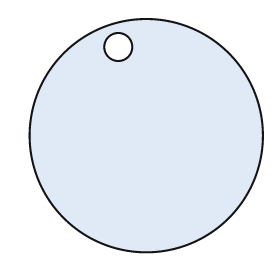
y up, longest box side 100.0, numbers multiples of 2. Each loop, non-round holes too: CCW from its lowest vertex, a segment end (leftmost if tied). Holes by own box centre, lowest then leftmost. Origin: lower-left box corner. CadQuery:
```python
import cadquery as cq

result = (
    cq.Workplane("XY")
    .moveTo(50.0, 50.0)
    .circle(50.0)
    .moveTo(38.0, 88.0)
    .circle(6.0)
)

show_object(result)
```